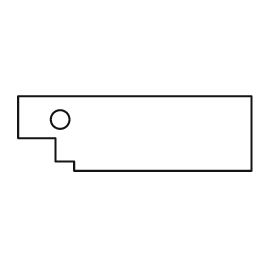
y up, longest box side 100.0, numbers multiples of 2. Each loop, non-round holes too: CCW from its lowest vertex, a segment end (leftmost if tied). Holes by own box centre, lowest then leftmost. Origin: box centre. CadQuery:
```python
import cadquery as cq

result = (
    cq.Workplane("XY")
    .moveTo(-26.0, -16.0)
    .lineTo(50.0, -16.0)
    .lineTo(50.0, 16.0)
    .lineTo(-50.0, 16.0)
    .lineTo(-50.0, -2.0)
    .lineTo(-34.0, -2.0)
    .lineTo(-34.0, -12.0)
    .lineTo(-26.0, -12.0)
    .close()
    .moveTo(-32.0, 6.0)
    .circle(4.0)
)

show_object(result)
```